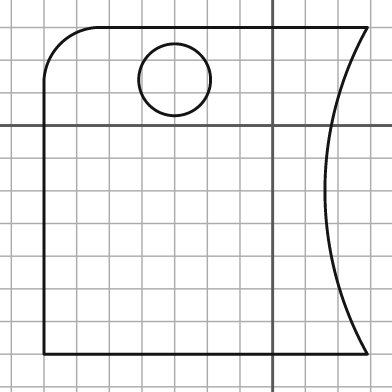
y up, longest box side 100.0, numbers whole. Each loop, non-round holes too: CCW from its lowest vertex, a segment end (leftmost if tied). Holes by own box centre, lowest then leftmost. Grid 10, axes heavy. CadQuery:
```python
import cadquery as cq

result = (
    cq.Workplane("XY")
    .moveTo(-70.0, -70.0)
    .lineTo(29.0, -70.0)
    .threePointArc((16.0, -20.0), (29.0, 30.0))
    .lineTo(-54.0, 30.0)
    .threePointArc((-65.0, 25.0), (-70.0, 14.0))
    .close()
    .moveTo(-30.0, 14.0)
    .circle(11.0)
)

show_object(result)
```